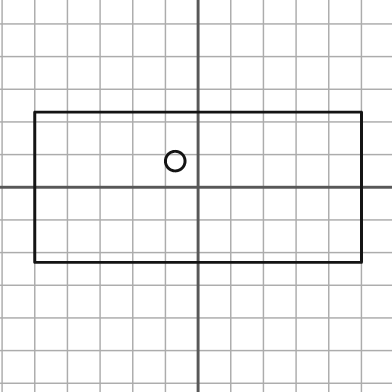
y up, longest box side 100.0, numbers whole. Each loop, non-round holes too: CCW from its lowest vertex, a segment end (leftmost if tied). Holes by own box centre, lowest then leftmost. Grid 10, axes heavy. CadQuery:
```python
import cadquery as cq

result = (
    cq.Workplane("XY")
    .moveTo(-50.0, -23.0)
    .lineTo(50.0, -23.0)
    .lineTo(50.0, 23.0)
    .lineTo(-50.0, 23.0)
    .close()
    .moveTo(-7.0, 8.0)
    .circle(3.0)
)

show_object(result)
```